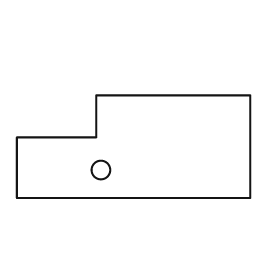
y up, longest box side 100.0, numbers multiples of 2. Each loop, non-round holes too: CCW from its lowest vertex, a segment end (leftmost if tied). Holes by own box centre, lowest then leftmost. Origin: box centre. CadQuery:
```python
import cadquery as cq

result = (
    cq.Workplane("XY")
    .moveTo(-50.0, -22.0)
    .lineTo(50.0, -22.0)
    .lineTo(50.0, 22.0)
    .lineTo(-16.0, 22.0)
    .lineTo(-16.0, 4.0)
    .lineTo(-50.0, 4.0)
    .close()
    .moveTo(-14.0, -10.0)
    .circle(4.0)
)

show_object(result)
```